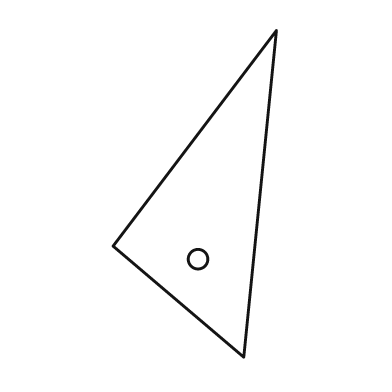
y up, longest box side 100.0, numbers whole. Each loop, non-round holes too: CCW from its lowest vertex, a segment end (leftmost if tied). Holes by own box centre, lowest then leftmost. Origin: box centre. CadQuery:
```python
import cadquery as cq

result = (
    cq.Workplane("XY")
    .moveTo(15.0, -50.0)
    .lineTo(25.0, 50.0)
    .lineTo(-25.0, -16.0)
    .close()
    .moveTo(1.0, -20.0)
    .circle(3.0)
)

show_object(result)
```